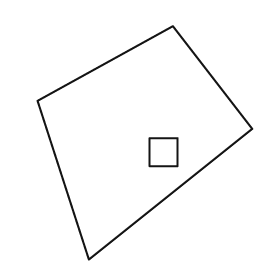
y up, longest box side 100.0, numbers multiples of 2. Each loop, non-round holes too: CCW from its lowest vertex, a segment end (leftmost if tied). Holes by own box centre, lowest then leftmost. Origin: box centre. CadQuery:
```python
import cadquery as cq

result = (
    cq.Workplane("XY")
    .moveTo(-24.0, -50.0)
    .lineTo(46.0, 6.0)
    .lineTo(12.0, 50.0)
    .lineTo(-46.0, 18.0)
    .close()
    .moveTo(2.0, -10.0)
    .lineTo(14.0, -10.0)
    .lineTo(14.0, 2.0)
    .lineTo(2.0, 2.0)
    .close()
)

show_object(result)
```